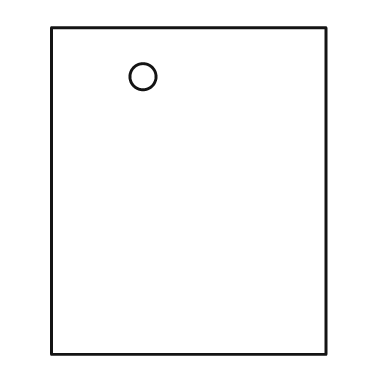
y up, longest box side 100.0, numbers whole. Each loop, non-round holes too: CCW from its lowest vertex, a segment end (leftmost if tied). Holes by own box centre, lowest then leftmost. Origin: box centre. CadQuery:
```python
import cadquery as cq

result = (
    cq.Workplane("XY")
    .moveTo(-42.0, -50.0)
    .lineTo(42.0, -50.0)
    .lineTo(42.0, 50.0)
    .lineTo(-42.0, 50.0)
    .close()
    .moveTo(-14.0, 35.0)
    .circle(4.0)
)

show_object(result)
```